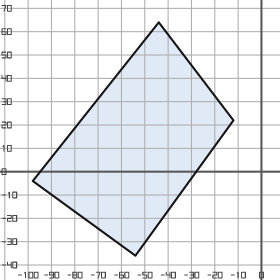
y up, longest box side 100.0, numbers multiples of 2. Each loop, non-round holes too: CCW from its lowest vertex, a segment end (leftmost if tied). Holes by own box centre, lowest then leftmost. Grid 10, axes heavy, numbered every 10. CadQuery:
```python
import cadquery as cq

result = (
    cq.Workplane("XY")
    .moveTo(-54.0, -36.0)
    .lineTo(-12.0, 22.0)
    .lineTo(-44.0, 64.0)
    .lineTo(-98.0, -4.0)
    .close()
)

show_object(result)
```